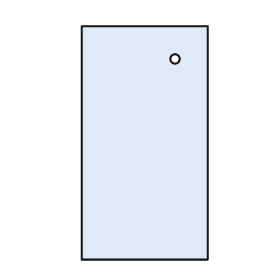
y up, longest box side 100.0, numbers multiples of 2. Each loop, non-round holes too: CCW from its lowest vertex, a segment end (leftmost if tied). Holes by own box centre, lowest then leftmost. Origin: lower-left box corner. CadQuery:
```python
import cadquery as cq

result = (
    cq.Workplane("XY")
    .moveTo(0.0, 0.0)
    .lineTo(54.0, 0.0)
    .lineTo(54.0, 100.0)
    .lineTo(0.0, 100.0)
    .close()
    .moveTo(40.0, 86.0)
    .circle(2.0)
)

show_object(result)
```